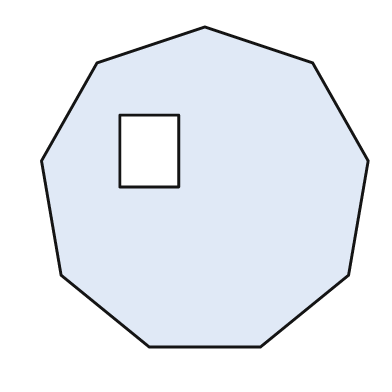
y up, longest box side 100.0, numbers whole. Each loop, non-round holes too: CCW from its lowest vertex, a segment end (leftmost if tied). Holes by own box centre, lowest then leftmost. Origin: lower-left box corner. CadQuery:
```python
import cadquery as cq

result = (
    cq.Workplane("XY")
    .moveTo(33.0, 0.0)
    .lineTo(67.0, 0.0)
    .lineTo(94.0, 22.0)
    .lineTo(100.0, 57.0)
    .lineTo(83.0, 87.0)
    .lineTo(50.0, 98.0)
    .lineTo(17.0, 87.0)
    .lineTo(0.0, 57.0)
    .lineTo(6.0, 22.0)
    .close()
    .moveTo(24.0, 49.0)
    .lineTo(42.0, 49.0)
    .lineTo(42.0, 71.0)
    .lineTo(24.0, 71.0)
    .close()
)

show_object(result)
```